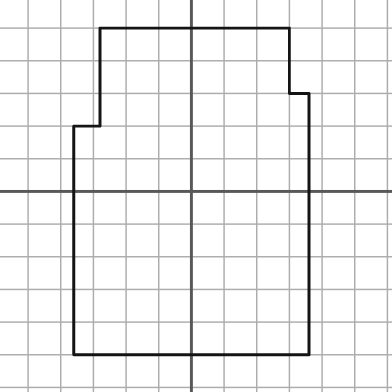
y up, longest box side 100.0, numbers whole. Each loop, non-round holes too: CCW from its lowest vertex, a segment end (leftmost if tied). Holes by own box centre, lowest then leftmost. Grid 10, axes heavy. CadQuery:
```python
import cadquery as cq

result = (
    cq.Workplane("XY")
    .moveTo(-36.0, -50.0)
    .lineTo(36.0, -50.0)
    .lineTo(36.0, 30.0)
    .lineTo(30.0, 30.0)
    .lineTo(30.0, 50.0)
    .lineTo(-28.0, 50.0)
    .lineTo(-28.0, 20.0)
    .lineTo(-36.0, 20.0)
    .close()
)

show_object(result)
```